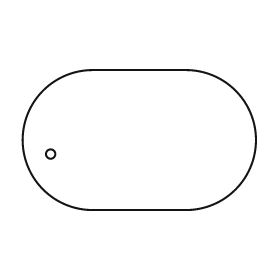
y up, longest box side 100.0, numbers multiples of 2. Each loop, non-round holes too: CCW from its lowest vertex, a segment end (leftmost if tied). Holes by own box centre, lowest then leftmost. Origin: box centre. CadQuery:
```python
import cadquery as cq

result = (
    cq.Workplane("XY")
    .moveTo(-20.0, -30.0)
    .lineTo(20.0, -30.0)
    .threePointArc((50.0, 0.0), (20.0, 30.0))
    .lineTo(-20.0, 30.0)
    .threePointArc((-50.0, 0.0), (-20.0, -30.0))
    .close()
    .moveTo(-38.0, -6.0)
    .circle(2.0)
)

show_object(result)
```